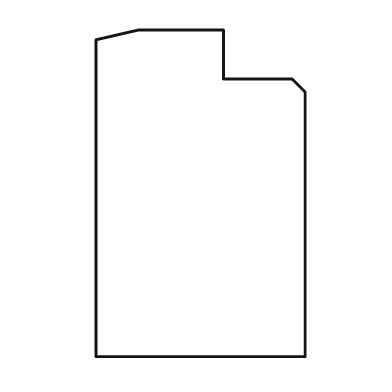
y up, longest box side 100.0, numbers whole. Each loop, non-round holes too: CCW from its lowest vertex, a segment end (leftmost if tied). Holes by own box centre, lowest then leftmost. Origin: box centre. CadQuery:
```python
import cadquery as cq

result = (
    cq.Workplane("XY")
    .moveTo(-32.0, -50.0)
    .lineTo(32.0, -50.0)
    .lineTo(32.0, 31.0)
    .lineTo(28.0, 35.0)
    .lineTo(7.0, 35.0)
    .lineTo(7.0, 50.0)
    .lineTo(-19.0, 50.0)
    .lineTo(-32.0, 47.0)
    .close()
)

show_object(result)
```